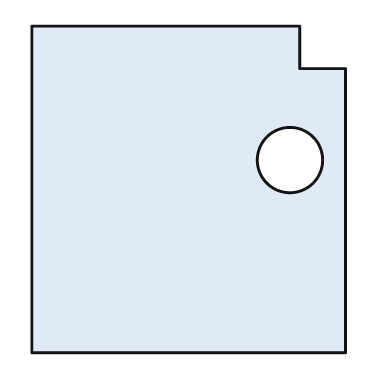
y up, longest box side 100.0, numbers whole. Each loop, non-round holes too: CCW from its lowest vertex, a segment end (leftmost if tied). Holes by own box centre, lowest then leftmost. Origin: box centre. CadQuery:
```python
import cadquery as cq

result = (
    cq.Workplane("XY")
    .moveTo(-48.0, -50.0)
    .lineTo(48.0, -50.0)
    .lineTo(48.0, 37.0)
    .lineTo(34.0, 37.0)
    .lineTo(34.0, 50.0)
    .lineTo(-48.0, 50.0)
    .close()
    .moveTo(31.0, 9.0)
    .circle(10.0)
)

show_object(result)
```